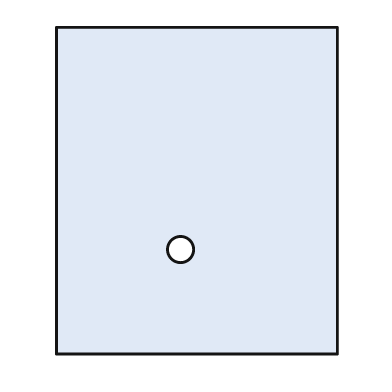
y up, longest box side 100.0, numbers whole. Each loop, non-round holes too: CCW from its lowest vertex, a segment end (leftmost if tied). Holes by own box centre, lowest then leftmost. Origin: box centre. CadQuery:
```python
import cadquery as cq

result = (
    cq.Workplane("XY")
    .moveTo(-43.0, -50.0)
    .lineTo(43.0, -50.0)
    .lineTo(43.0, 50.0)
    .lineTo(-43.0, 50.0)
    .close()
    .moveTo(-5.0, -18.0)
    .circle(4.0)
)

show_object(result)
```